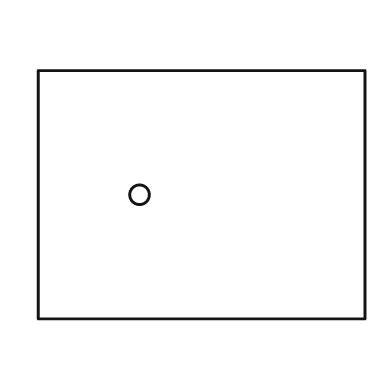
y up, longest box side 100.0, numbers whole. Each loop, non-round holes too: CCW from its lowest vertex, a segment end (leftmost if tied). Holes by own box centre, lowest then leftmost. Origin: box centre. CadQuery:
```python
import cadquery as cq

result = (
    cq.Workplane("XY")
    .moveTo(-50.0, -38.0)
    .lineTo(50.0, -38.0)
    .lineTo(50.0, 38.0)
    .lineTo(-50.0, 38.0)
    .close()
    .moveTo(-19.0, 0.0)
    .circle(3.0)
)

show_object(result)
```